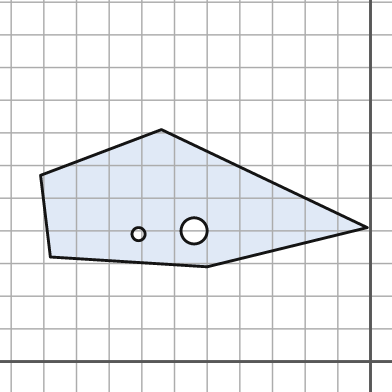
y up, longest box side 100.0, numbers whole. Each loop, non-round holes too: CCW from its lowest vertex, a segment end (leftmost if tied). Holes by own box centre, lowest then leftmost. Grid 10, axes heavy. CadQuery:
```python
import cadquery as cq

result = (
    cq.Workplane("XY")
    .moveTo(-50.0, 29.0)
    .lineTo(-1.0, 41.0)
    .lineTo(-64.0, 71.0)
    .lineTo(-101.0, 57.0)
    .lineTo(-98.0, 32.0)
    .close()
    .moveTo(-71.0, 39.0)
    .circle(2.0)
    .moveTo(-54.0, 40.0)
    .circle(4.0)
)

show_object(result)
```